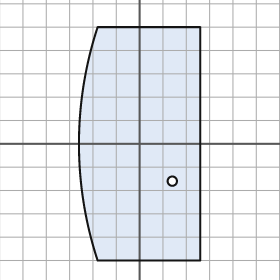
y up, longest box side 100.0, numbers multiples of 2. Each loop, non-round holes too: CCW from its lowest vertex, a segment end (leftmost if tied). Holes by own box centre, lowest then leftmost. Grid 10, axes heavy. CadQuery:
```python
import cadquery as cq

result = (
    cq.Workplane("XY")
    .moveTo(-18.0, -50.0)
    .lineTo(26.0, -50.0)
    .lineTo(26.0, 50.0)
    .lineTo(-18.0, 50.0)
    .threePointArc((-26.0, 0.0), (-18.0, -50.0))
    .close()
    .moveTo(14.0, -16.0)
    .circle(2.0)
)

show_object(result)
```